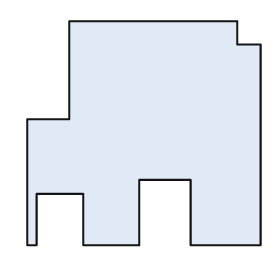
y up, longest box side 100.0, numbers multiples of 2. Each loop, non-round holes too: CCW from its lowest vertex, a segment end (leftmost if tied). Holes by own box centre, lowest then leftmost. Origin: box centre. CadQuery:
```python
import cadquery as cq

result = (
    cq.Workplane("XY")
    .moveTo(-50.0, -48.0)
    .lineTo(-46.0, -48.0)
    .lineTo(-46.0, -26.0)
    .lineTo(-26.0, -26.0)
    .lineTo(-26.0, -48.0)
    .lineTo(-2.0, -48.0)
    .lineTo(-2.0, -20.0)
    .lineTo(20.0, -20.0)
    .lineTo(20.0, -48.0)
    .lineTo(50.0, -48.0)
    .lineTo(50.0, 38.0)
    .lineTo(40.0, 38.0)
    .lineTo(40.0, 48.0)
    .lineTo(-32.0, 48.0)
    .lineTo(-32.0, 6.0)
    .lineTo(-50.0, 6.0)
    .close()
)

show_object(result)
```